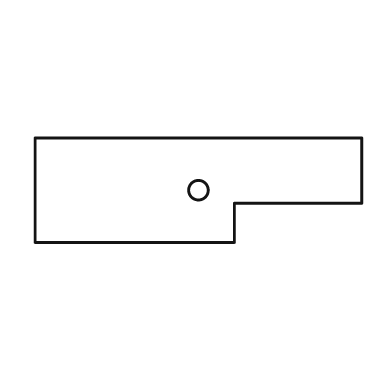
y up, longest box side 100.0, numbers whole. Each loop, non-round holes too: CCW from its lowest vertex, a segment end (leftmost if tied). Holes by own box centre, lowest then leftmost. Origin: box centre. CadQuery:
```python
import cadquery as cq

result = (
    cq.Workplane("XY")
    .moveTo(-50.0, -16.0)
    .lineTo(11.0, -16.0)
    .lineTo(11.0, -4.0)
    .lineTo(50.0, -4.0)
    .lineTo(50.0, 16.0)
    .lineTo(-50.0, 16.0)
    .close()
    .moveTo(0.0, 0.0)
    .circle(3.0)
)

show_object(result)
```